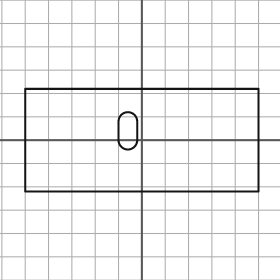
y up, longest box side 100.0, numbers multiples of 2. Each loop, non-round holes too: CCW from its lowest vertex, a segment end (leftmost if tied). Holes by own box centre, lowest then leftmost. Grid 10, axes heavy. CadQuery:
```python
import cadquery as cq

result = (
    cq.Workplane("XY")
    .moveTo(-50.0, -22.0)
    .lineTo(50.0, -22.0)
    .lineTo(50.0, 22.0)
    .lineTo(-50.0, 22.0)
    .close()
    .moveTo(-10.0, 0.0)
    .threePointArc((-6.0, -4.0), (-2.0, 0.0))
    .lineTo(-2.0, 8.0)
    .threePointArc((-6.0, 12.0), (-10.0, 8.0))
    .close()
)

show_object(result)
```